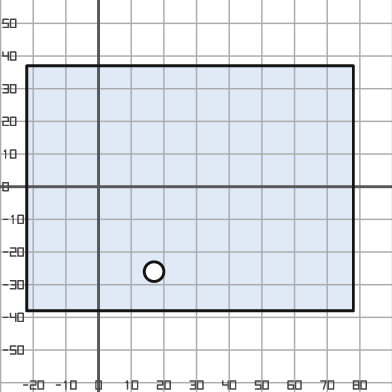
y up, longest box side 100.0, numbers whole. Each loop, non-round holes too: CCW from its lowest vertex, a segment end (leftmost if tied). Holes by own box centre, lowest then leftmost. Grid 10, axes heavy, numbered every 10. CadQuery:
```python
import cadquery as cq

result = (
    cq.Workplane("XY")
    .moveTo(-22.0, -38.0)
    .lineTo(78.0, -38.0)
    .lineTo(78.0, 37.0)
    .lineTo(-22.0, 37.0)
    .close()
    .moveTo(17.0, -26.0)
    .circle(3.0)
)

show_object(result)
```